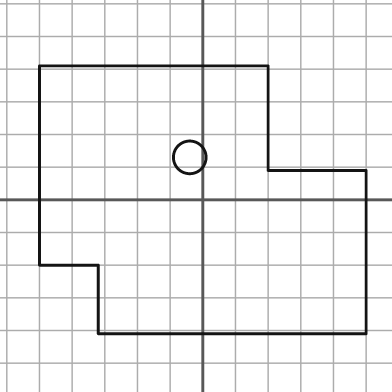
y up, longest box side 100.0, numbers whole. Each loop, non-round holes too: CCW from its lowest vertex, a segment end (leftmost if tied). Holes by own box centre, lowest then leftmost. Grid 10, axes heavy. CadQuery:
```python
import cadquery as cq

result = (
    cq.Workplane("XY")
    .moveTo(-32.0, -41.0)
    .lineTo(50.0, -41.0)
    .lineTo(50.0, 9.0)
    .lineTo(20.0, 9.0)
    .lineTo(20.0, 41.0)
    .lineTo(-50.0, 41.0)
    .lineTo(-50.0, -20.0)
    .lineTo(-32.0, -20.0)
    .close()
    .moveTo(-4.0, 13.0)
    .circle(5.0)
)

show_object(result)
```